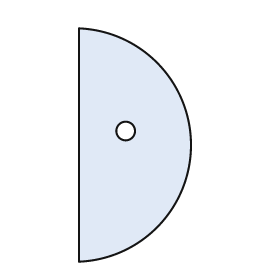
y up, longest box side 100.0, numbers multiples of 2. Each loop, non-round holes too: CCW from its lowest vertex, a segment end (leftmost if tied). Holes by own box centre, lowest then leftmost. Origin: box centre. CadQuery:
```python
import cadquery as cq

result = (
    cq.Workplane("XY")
    .moveTo(-24.0, -50.0)
    .threePointArc((24.0, 0.0), (-24.0, 50.0))
    .close()
    .moveTo(-4.0, 6.0)
    .circle(4.0)
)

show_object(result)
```